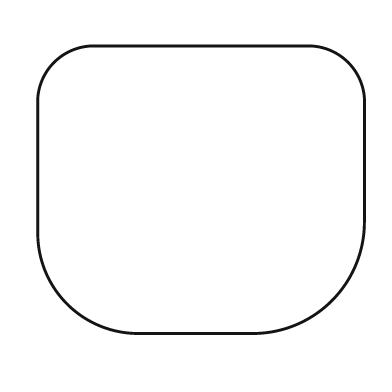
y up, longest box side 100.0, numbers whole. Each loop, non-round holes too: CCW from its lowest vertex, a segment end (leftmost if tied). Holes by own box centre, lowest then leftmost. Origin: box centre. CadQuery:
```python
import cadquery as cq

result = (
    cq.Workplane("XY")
    .moveTo(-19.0, -44.0)
    .lineTo(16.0, -44.0)
    .threePointArc((40.0, -34.0), (50.0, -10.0))
    .lineTo(50.0, 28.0)
    .threePointArc((45.0, 39.0), (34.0, 44.0))
    .lineTo(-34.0, 44.0)
    .threePointArc((-45.0, 39.0), (-50.0, 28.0))
    .lineTo(-50.0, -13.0)
    .threePointArc((-41.0, -35.0), (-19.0, -44.0))
    .close()
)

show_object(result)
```